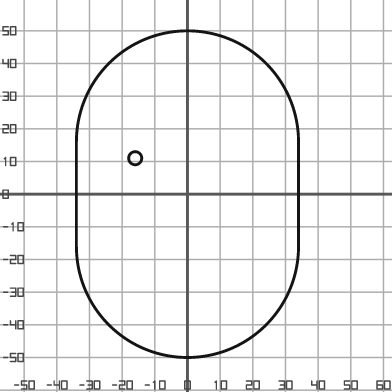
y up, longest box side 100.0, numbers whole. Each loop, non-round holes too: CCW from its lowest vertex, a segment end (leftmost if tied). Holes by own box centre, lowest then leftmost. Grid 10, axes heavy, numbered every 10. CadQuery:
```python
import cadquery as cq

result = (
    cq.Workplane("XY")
    .moveTo(-34.0, -16.0)
    .threePointArc((0.0, -50.0), (34.0, -16.0))
    .lineTo(34.0, 16.0)
    .threePointArc((0.0, 50.0), (-34.0, 16.0))
    .close()
    .moveTo(-16.0, 11.0)
    .circle(2.0)
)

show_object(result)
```